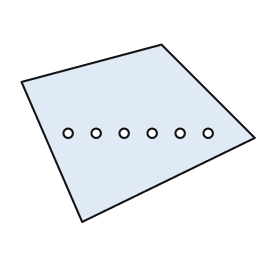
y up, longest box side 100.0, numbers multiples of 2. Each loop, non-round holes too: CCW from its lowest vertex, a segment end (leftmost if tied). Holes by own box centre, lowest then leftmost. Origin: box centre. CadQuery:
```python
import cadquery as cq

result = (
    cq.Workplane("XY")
    .moveTo(-24.0, -38.0)
    .lineTo(50.0, -2.0)
    .lineTo(10.0, 38.0)
    .lineTo(-50.0, 22.0)
    .close()
    .moveTo(-30.0, 0.0)
    .circle(2.0)
    .moveTo(-18.0, 0.0)
    .circle(2.0)
    .moveTo(-6.0, 0.0)
    .circle(2.0)
    .moveTo(6.0, 0.0)
    .circle(2.0)
    .moveTo(18.0, 0.0)
    .circle(2.0)
    .moveTo(30.0, 0.0)
    .circle(2.0)
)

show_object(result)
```